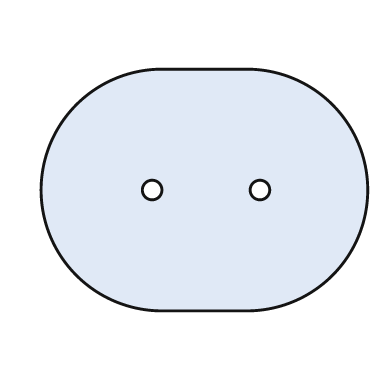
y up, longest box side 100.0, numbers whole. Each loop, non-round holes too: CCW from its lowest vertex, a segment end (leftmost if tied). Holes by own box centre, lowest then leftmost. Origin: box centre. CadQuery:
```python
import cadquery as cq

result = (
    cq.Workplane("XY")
    .moveTo(-13.0, -37.0)
    .lineTo(13.0, -37.0)
    .threePointArc((50.0, 0.0), (13.0, 37.0))
    .lineTo(-13.0, 37.0)
    .threePointArc((-50.0, 0.0), (-13.0, -37.0))
    .close()
    .moveTo(-16.0, 0.0)
    .circle(3.0)
    .moveTo(17.0, 0.0)
    .circle(3.0)
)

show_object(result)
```